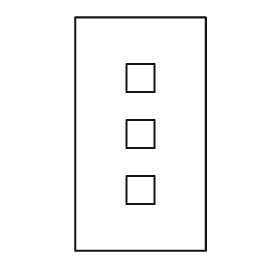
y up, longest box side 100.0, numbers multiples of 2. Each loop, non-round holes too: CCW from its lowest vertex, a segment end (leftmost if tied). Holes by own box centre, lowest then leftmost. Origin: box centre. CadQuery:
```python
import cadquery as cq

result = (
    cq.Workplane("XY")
    .moveTo(-28.0, -50.0)
    .lineTo(28.0, -50.0)
    .lineTo(28.0, 50.0)
    .lineTo(-28.0, 50.0)
    .close()
    .moveTo(-6.0, -30.0)
    .lineTo(6.0, -30.0)
    .lineTo(6.0, -18.0)
    .lineTo(-6.0, -18.0)
    .close()
    .moveTo(-6.0, -6.0)
    .lineTo(6.0, -6.0)
    .lineTo(6.0, 6.0)
    .lineTo(-6.0, 6.0)
    .close()
    .moveTo(-6.0, 18.0)
    .lineTo(6.0, 18.0)
    .lineTo(6.0, 30.0)
    .lineTo(-6.0, 30.0)
    .close()
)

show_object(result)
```